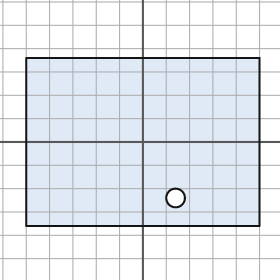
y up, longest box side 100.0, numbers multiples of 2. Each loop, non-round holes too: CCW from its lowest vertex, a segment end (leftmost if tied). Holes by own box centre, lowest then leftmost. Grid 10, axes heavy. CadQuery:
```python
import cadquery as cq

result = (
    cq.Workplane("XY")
    .moveTo(-50.0, -36.0)
    .lineTo(50.0, -36.0)
    .lineTo(50.0, 36.0)
    .lineTo(-50.0, 36.0)
    .close()
    .moveTo(14.0, -24.0)
    .circle(4.0)
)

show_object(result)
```